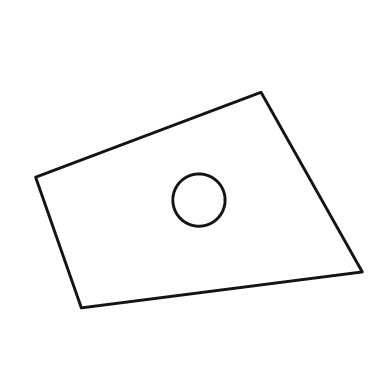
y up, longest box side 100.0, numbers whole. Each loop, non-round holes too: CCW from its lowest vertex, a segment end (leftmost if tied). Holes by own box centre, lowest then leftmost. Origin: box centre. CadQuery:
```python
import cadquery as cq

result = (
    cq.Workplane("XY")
    .moveTo(-36.0, -33.0)
    .lineTo(50.0, -22.0)
    .lineTo(19.0, 33.0)
    .lineTo(-50.0, 7.0)
    .close()
    .moveTo(0.0, 0.0)
    .circle(8.0)
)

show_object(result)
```